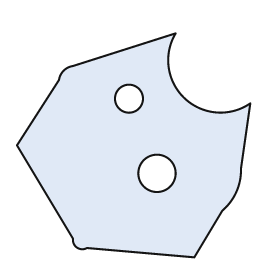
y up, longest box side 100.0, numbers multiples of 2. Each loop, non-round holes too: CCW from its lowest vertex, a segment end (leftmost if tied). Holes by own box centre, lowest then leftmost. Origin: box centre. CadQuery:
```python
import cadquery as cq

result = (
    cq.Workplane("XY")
    .moveTo(26.0, -48.0)
    .lineTo(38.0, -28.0)
    .threePointArc((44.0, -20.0), (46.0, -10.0))
    .lineTo(50.0, 18.0)
    .threePointArc((22.0, 20.0), (18.0, 48.0))
    .lineTo(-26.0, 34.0)
    .threePointArc((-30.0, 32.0), (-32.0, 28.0))
    .lineTo(-50.0, 0.0)
    .lineTo(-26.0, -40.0)
    .threePointArc((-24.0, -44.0), (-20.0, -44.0))
    .close()
    .moveTo(10.0, -12.0)
    .circle(8.0)
    .moveTo(-2.0, 20.0)
    .circle(6.0)
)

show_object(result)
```